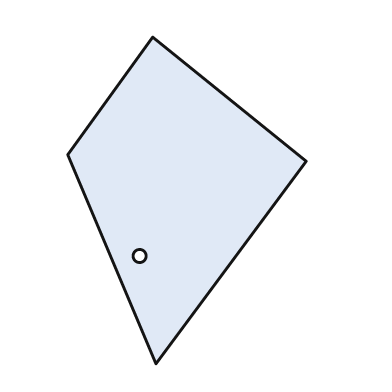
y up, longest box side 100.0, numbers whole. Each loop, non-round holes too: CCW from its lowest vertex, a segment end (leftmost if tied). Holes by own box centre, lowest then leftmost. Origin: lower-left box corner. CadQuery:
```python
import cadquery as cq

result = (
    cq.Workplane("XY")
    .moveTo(27.0, 0.0)
    .lineTo(73.0, 62.0)
    .lineTo(26.0, 100.0)
    .lineTo(0.0, 64.0)
    .close()
    .moveTo(22.0, 33.0)
    .circle(2.0)
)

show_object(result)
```